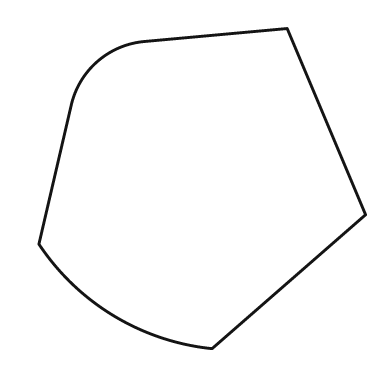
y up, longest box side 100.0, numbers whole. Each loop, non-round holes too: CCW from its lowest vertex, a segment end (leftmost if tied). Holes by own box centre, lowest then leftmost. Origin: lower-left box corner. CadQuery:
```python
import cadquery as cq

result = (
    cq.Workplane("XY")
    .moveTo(53.0, 0.0)
    .lineTo(100.0, 41.0)
    .lineTo(76.0, 98.0)
    .lineTo(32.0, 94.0)
    .threePointArc((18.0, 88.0), (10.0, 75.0))
    .lineTo(0.0, 32.0)
    .threePointArc((23.0, 10.0), (53.0, 0.0))
    .close()
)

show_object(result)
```